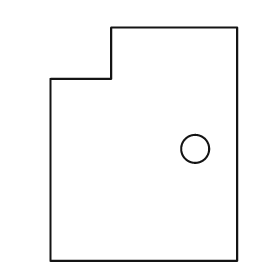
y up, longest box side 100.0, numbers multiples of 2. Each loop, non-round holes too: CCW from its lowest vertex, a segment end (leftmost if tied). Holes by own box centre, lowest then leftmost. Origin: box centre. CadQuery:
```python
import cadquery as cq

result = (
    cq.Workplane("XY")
    .moveTo(-40.0, -50.0)
    .lineTo(40.0, -50.0)
    .lineTo(40.0, 50.0)
    .lineTo(-14.0, 50.0)
    .lineTo(-14.0, 28.0)
    .lineTo(-40.0, 28.0)
    .close()
    .moveTo(22.0, -2.0)
    .circle(6.0)
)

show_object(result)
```